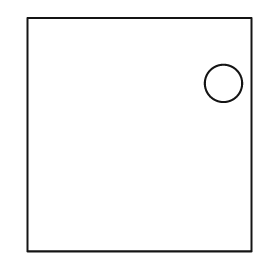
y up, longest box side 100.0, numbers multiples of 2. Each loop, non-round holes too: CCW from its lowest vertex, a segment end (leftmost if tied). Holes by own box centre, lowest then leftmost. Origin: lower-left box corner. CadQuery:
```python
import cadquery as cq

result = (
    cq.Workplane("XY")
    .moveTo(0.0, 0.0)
    .lineTo(96.0, 0.0)
    .lineTo(96.0, 100.0)
    .lineTo(0.0, 100.0)
    .close()
    .moveTo(84.0, 72.0)
    .circle(8.0)
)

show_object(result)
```